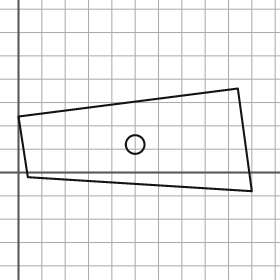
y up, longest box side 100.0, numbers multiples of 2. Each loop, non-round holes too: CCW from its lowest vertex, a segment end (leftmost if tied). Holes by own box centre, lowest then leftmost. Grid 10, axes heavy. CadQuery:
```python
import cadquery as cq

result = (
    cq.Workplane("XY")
    .moveTo(100.0, -8.0)
    .lineTo(94.0, 36.0)
    .lineTo(0.0, 24.0)
    .lineTo(4.0, -2.0)
    .close()
    .moveTo(50.0, 12.0)
    .circle(4.0)
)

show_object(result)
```